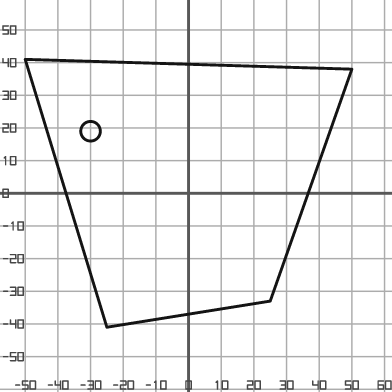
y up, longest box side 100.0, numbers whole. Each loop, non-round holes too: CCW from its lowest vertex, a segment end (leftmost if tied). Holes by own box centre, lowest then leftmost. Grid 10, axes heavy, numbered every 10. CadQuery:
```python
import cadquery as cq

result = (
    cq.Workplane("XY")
    .moveTo(-25.0, -41.0)
    .lineTo(25.0, -33.0)
    .lineTo(50.0, 38.0)
    .lineTo(-50.0, 41.0)
    .close()
    .moveTo(-30.0, 19.0)
    .circle(3.0)
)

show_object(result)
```